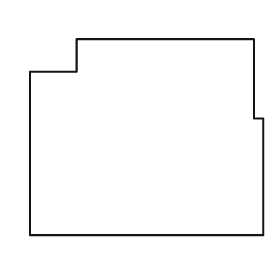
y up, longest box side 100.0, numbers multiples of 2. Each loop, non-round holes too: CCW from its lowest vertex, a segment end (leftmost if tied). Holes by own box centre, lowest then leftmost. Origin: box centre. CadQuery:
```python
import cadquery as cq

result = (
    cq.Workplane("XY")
    .moveTo(-50.0, -42.0)
    .lineTo(50.0, -42.0)
    .lineTo(50.0, 8.0)
    .lineTo(46.0, 8.0)
    .lineTo(46.0, 42.0)
    .lineTo(-30.0, 42.0)
    .lineTo(-30.0, 28.0)
    .lineTo(-50.0, 28.0)
    .close()
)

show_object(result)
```